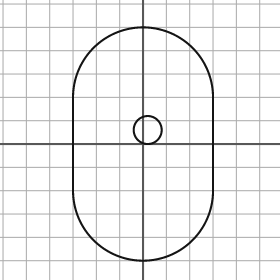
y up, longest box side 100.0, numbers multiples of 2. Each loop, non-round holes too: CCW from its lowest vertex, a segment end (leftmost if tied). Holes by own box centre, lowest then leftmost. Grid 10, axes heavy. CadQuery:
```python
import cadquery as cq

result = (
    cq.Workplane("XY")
    .moveTo(-30.0, -20.0)
    .threePointArc((0.0, -50.0), (30.0, -20.0))
    .lineTo(30.0, 20.0)
    .threePointArc((0.0, 50.0), (-30.0, 20.0))
    .close()
    .moveTo(2.0, 6.0)
    .circle(6.0)
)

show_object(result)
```